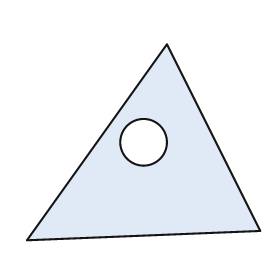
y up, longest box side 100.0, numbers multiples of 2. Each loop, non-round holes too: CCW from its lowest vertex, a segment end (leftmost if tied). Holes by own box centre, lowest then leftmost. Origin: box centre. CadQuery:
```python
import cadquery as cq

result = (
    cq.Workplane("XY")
    .moveTo(-50.0, -42.0)
    .lineTo(50.0, -38.0)
    .lineTo(10.0, 42.0)
    .close()
    .moveTo(0.0, 0.0)
    .circle(10.0)
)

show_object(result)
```